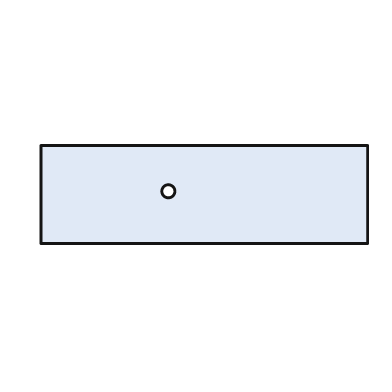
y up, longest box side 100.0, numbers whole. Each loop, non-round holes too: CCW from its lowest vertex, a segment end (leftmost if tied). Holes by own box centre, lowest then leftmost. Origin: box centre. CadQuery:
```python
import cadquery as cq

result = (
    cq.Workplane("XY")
    .moveTo(-50.0, -15.0)
    .lineTo(50.0, -15.0)
    .lineTo(50.0, 15.0)
    .lineTo(-50.0, 15.0)
    .close()
    .moveTo(-11.0, 1.0)
    .circle(2.0)
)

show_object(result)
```